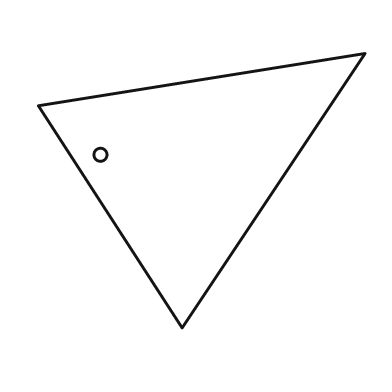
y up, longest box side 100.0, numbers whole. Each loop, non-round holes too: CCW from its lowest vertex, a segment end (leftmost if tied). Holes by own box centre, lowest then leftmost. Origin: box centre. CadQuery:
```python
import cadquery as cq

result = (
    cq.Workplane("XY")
    .moveTo(-6.0, -42.0)
    .lineTo(50.0, 42.0)
    .lineTo(-50.0, 26.0)
    .close()
    .moveTo(-31.0, 11.0)
    .circle(2.0)
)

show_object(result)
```